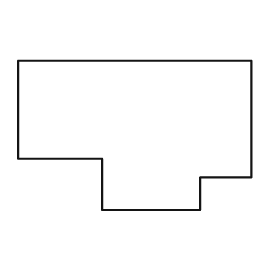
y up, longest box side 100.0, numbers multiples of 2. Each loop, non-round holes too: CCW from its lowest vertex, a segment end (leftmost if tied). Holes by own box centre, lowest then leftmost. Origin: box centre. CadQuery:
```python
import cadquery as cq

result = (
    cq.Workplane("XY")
    .moveTo(-14.0, -32.0)
    .lineTo(28.0, -32.0)
    .lineTo(28.0, -18.0)
    .lineTo(50.0, -18.0)
    .lineTo(50.0, 32.0)
    .lineTo(-50.0, 32.0)
    .lineTo(-50.0, -10.0)
    .lineTo(-14.0, -10.0)
    .close()
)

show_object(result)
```